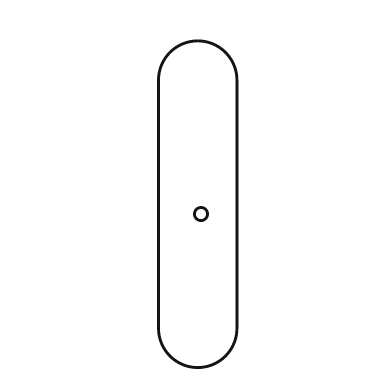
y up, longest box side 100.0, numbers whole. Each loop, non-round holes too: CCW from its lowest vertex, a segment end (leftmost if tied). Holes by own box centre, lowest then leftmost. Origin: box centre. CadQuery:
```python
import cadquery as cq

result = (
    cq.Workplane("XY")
    .moveTo(-12.0, -38.0)
    .threePointArc((0.0, -50.0), (12.0, -38.0))
    .lineTo(12.0, 38.0)
    .threePointArc((0.0, 50.0), (-12.0, 38.0))
    .close()
    .moveTo(1.0, -3.0)
    .circle(2.0)
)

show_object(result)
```